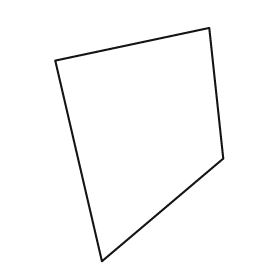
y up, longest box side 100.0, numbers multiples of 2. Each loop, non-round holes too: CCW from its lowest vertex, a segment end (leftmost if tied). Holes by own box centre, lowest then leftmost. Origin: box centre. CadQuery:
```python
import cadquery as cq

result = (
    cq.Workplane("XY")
    .moveTo(-16.0, -50.0)
    .lineTo(36.0, -6.0)
    .lineTo(30.0, 50.0)
    .lineTo(-36.0, 36.0)
    .close()
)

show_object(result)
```